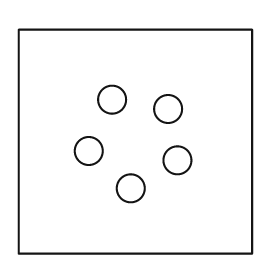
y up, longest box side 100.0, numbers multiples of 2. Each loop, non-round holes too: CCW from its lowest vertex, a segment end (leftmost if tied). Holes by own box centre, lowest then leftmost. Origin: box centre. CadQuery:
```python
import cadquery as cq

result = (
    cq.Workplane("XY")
    .moveTo(-50.0, -48.0)
    .lineTo(50.0, -48.0)
    .lineTo(50.0, 48.0)
    .lineTo(-50.0, 48.0)
    .close()
    .moveTo(-2.0, -20.0)
    .circle(6.0)
    .moveTo(18.0, -8.0)
    .circle(6.0)
    .moveTo(-20.0, -4.0)
    .circle(6.0)
    .moveTo(14.0, 14.0)
    .circle(6.0)
    .moveTo(-10.0, 18.0)
    .circle(6.0)
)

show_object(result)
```